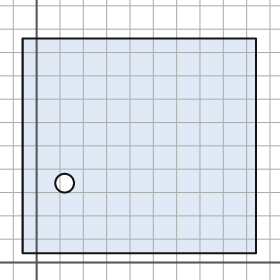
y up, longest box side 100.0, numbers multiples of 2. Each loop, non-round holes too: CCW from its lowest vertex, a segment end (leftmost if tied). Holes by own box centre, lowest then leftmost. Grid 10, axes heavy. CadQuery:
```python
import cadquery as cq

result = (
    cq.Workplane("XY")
    .moveTo(-6.0, 4.0)
    .lineTo(94.0, 4.0)
    .lineTo(94.0, 96.0)
    .lineTo(-6.0, 96.0)
    .close()
    .moveTo(12.0, 34.0)
    .circle(4.0)
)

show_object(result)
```